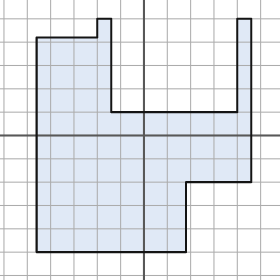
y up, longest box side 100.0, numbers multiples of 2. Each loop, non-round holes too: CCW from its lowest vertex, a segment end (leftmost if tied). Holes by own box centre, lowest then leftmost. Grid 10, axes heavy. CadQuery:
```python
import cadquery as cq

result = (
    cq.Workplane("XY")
    .moveTo(-46.0, -50.0)
    .lineTo(18.0, -50.0)
    .lineTo(18.0, -20.0)
    .lineTo(46.0, -20.0)
    .lineTo(46.0, 50.0)
    .lineTo(40.0, 50.0)
    .lineTo(40.0, 10.0)
    .lineTo(-14.0, 10.0)
    .lineTo(-14.0, 50.0)
    .lineTo(-20.0, 50.0)
    .lineTo(-20.0, 42.0)
    .lineTo(-46.0, 42.0)
    .close()
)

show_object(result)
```